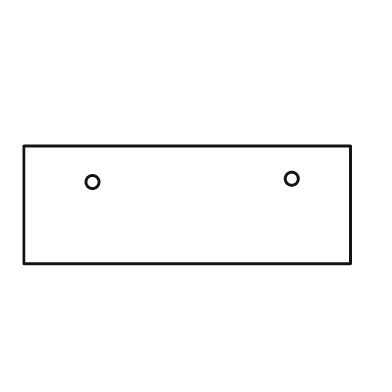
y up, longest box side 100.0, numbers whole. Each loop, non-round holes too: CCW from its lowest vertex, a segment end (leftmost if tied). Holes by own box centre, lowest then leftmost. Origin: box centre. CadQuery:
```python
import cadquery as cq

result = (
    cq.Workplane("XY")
    .moveTo(-50.0, -18.0)
    .lineTo(50.0, -18.0)
    .lineTo(50.0, 18.0)
    .lineTo(-50.0, 18.0)
    .close()
    .moveTo(-29.0, 7.0)
    .circle(2.0)
    .moveTo(32.0, 8.0)
    .circle(2.0)
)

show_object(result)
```